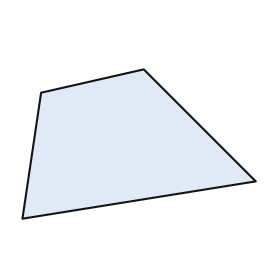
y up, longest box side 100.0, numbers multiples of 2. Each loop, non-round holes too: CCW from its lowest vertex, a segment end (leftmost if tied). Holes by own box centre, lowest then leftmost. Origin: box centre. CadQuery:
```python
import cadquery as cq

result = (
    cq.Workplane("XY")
    .moveTo(-50.0, -32.0)
    .lineTo(50.0, -16.0)
    .lineTo(2.0, 32.0)
    .lineTo(-42.0, 22.0)
    .close()
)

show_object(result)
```